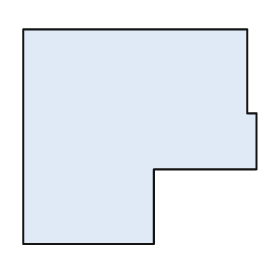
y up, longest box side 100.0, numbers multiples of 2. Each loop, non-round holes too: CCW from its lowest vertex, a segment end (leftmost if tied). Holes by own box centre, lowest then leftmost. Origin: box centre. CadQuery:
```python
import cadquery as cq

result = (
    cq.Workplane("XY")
    .moveTo(-50.0, -46.0)
    .lineTo(6.0, -46.0)
    .lineTo(6.0, -14.0)
    .lineTo(50.0, -14.0)
    .lineTo(50.0, 10.0)
    .lineTo(46.0, 10.0)
    .lineTo(46.0, 46.0)
    .lineTo(-50.0, 46.0)
    .close()
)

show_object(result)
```